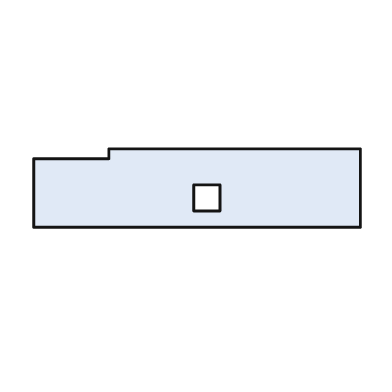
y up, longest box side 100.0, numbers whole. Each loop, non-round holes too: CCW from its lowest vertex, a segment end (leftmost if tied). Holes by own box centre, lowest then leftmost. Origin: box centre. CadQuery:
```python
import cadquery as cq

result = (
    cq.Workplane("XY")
    .moveTo(-50.0, -12.0)
    .lineTo(50.0, -12.0)
    .lineTo(50.0, 12.0)
    .lineTo(-27.0, 12.0)
    .lineTo(-27.0, 9.0)
    .lineTo(-50.0, 9.0)
    .close()
    .moveTo(-1.0, -7.0)
    .lineTo(7.0, -7.0)
    .lineTo(7.0, 1.0)
    .lineTo(-1.0, 1.0)
    .close()
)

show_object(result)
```